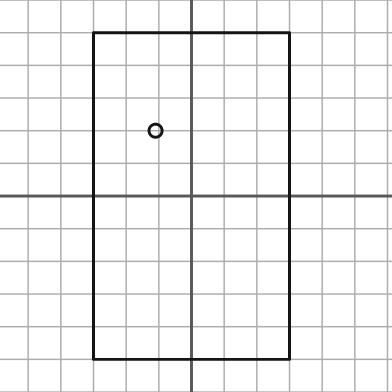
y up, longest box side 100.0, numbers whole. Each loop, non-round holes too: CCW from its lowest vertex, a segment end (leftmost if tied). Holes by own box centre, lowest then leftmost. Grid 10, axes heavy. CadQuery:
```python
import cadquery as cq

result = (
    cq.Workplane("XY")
    .moveTo(-30.0, -50.0)
    .lineTo(30.0, -50.0)
    .lineTo(30.0, 50.0)
    .lineTo(-30.0, 50.0)
    .close()
    .moveTo(-11.0, 20.0)
    .circle(2.0)
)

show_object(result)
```